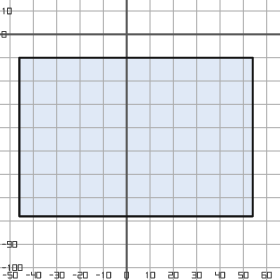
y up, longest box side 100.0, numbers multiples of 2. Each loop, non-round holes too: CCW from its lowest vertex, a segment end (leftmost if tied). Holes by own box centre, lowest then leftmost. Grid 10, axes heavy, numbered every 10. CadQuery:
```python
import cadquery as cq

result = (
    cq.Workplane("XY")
    .moveTo(-46.0, -78.0)
    .lineTo(54.0, -78.0)
    .lineTo(54.0, -10.0)
    .lineTo(-46.0, -10.0)
    .close()
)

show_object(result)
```